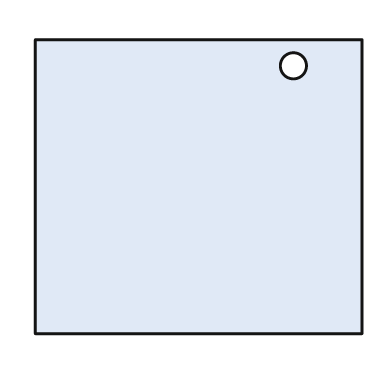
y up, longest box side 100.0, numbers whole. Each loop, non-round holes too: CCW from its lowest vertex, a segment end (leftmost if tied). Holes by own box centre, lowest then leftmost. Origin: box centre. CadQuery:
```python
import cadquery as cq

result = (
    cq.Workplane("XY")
    .moveTo(-50.0, -45.0)
    .lineTo(50.0, -45.0)
    .lineTo(50.0, 45.0)
    .lineTo(-50.0, 45.0)
    .close()
    .moveTo(29.0, 37.0)
    .circle(4.0)
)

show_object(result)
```